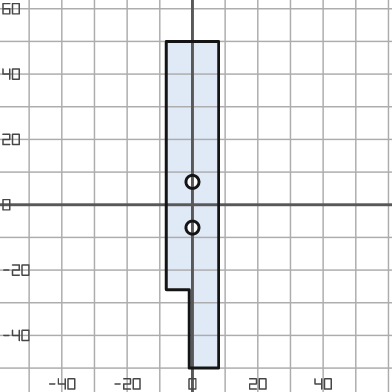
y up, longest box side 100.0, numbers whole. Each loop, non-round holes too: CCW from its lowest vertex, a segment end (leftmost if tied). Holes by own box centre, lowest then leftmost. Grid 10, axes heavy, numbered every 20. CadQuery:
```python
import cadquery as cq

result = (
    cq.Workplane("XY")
    .moveTo(-1.0, -50.0)
    .lineTo(8.0, -50.0)
    .lineTo(8.0, 50.0)
    .lineTo(-8.0, 50.0)
    .lineTo(-8.0, -26.0)
    .lineTo(-1.0, -26.0)
    .close()
    .moveTo(0.0, -7.0)
    .circle(2.0)
    .moveTo(0.0, 7.0)
    .circle(2.0)
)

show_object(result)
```